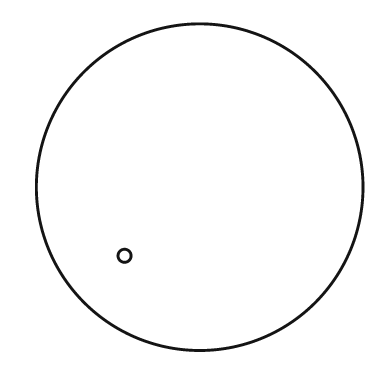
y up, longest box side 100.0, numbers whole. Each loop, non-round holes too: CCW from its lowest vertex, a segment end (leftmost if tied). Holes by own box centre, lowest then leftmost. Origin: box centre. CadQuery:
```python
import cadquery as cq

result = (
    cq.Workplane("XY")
    .moveTo(0.0, 0.0)
    .circle(50.0)
    .moveTo(-23.0, -21.0)
    .circle(2.0)
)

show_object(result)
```